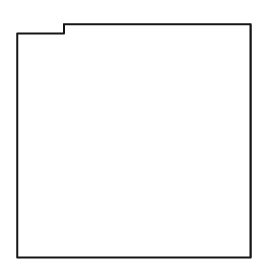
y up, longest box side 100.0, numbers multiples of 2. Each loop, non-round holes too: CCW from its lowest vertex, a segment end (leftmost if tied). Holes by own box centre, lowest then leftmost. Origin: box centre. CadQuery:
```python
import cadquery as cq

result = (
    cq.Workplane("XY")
    .moveTo(-50.0, -50.0)
    .lineTo(50.0, -50.0)
    .lineTo(50.0, 50.0)
    .lineTo(-30.0, 50.0)
    .lineTo(-30.0, 46.0)
    .lineTo(-50.0, 46.0)
    .close()
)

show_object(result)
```